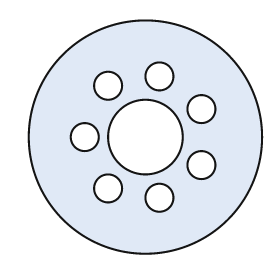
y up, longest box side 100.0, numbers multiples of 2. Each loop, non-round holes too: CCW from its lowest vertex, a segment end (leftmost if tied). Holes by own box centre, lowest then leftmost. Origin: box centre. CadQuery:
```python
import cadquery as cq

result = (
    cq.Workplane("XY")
    .moveTo(0.0, 0.0)
    .circle(50.0)
    .moveTo(6.0, -26.0)
    .circle(6.0)
    .moveTo(-16.0, -22.0)
    .circle(6.0)
    .moveTo(24.0, -12.0)
    .circle(6.0)
    .moveTo(-26.0, 0.0)
    .circle(6.0)
    .moveTo(0.0, 0.0)
    .circle(16.0)
    .moveTo(24.0, 12.0)
    .circle(6.0)
    .moveTo(-16.0, 22.0)
    .circle(6.0)
    .moveTo(6.0, 26.0)
    .circle(6.0)
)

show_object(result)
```